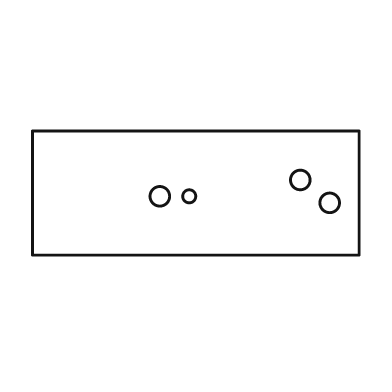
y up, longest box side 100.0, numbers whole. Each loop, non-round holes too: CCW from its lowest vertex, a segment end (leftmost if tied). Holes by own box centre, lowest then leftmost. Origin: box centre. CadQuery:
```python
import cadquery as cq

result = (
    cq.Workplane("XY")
    .moveTo(-50.0, -19.0)
    .lineTo(50.0, -19.0)
    .lineTo(50.0, 19.0)
    .lineTo(-50.0, 19.0)
    .close()
    .moveTo(41.0, -3.0)
    .circle(3.0)
    .moveTo(-11.0, -1.0)
    .circle(3.0)
    .moveTo(-2.0, -1.0)
    .circle(2.0)
    .moveTo(32.0, 4.0)
    .circle(3.0)
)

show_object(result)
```